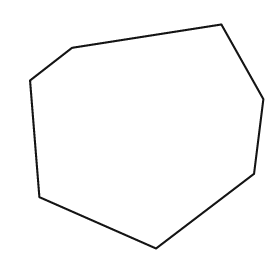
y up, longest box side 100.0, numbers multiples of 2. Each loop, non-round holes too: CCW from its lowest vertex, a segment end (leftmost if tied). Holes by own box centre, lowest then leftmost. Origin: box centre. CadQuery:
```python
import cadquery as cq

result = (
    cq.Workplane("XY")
    .moveTo(4.0, -48.0)
    .lineTo(46.0, -16.0)
    .lineTo(50.0, 16.0)
    .lineTo(32.0, 48.0)
    .lineTo(-32.0, 38.0)
    .lineTo(-50.0, 24.0)
    .lineTo(-46.0, -26.0)
    .close()
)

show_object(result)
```